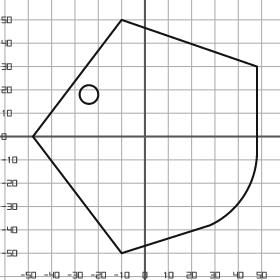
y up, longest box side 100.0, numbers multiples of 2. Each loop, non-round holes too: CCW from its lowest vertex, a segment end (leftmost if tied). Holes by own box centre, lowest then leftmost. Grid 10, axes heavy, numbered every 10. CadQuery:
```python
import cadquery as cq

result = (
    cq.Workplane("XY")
    .moveTo(-10.0, -50.0)
    .lineTo(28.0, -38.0)
    .threePointArc((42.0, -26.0), (48.0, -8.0))
    .lineTo(48.0, 30.0)
    .lineTo(-10.0, 50.0)
    .lineTo(-48.0, 0.0)
    .close()
    .moveTo(-24.0, 18.0)
    .circle(4.0)
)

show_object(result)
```